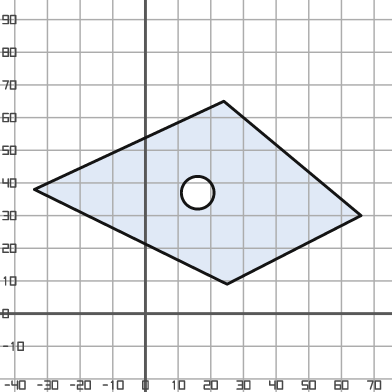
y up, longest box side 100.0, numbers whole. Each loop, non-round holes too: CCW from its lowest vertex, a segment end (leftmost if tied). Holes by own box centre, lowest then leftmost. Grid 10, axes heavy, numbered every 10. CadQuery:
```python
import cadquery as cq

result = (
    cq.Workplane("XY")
    .moveTo(25.0, 9.0)
    .lineTo(66.0, 30.0)
    .lineTo(24.0, 65.0)
    .lineTo(-34.0, 38.0)
    .close()
    .moveTo(16.0, 37.0)
    .circle(5.0)
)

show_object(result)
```